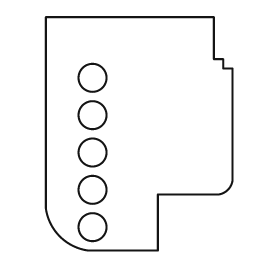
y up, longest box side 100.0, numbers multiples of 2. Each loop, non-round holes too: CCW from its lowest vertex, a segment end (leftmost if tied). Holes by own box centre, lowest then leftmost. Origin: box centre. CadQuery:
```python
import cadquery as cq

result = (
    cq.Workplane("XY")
    .moveTo(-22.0, -50.0)
    .lineTo(8.0, -50.0)
    .lineTo(8.0, -26.0)
    .lineTo(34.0, -26.0)
    .threePointArc((38.0, -24.0), (40.0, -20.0))
    .lineTo(40.0, 28.0)
    .lineTo(36.0, 28.0)
    .lineTo(36.0, 32.0)
    .lineTo(32.0, 32.0)
    .lineTo(32.0, 50.0)
    .lineTo(-40.0, 50.0)
    .lineTo(-40.0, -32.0)
    .threePointArc((-34.0, -44.0), (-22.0, -50.0))
    .close()
    .moveTo(-20.0, -40.0)
    .circle(6.0)
    .moveTo(-20.0, -24.0)
    .circle(6.0)
    .moveTo(-20.0, -8.0)
    .circle(6.0)
    .moveTo(-20.0, 8.0)
    .circle(6.0)
    .moveTo(-20.0, 24.0)
    .circle(6.0)
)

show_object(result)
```